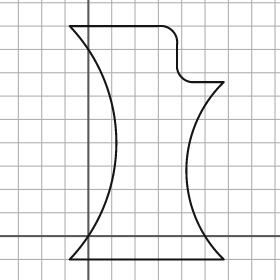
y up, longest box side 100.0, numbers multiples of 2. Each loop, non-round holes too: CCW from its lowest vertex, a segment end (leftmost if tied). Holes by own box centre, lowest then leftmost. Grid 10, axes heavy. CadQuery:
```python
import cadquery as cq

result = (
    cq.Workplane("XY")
    .moveTo(-8.0, -10.0)
    .lineTo(58.0, -10.0)
    .threePointArc((42.0, 28.0), (58.0, 66.0))
    .lineTo(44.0, 66.0)
    .threePointArc((40.0, 68.0), (38.0, 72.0))
    .lineTo(38.0, 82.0)
    .threePointArc((36.0, 88.0), (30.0, 90.0))
    .lineTo(-8.0, 90.0)
    .threePointArc((12.0, 40.0), (-8.0, -10.0))
    .close()
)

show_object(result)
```